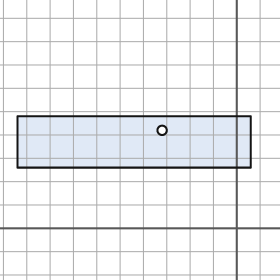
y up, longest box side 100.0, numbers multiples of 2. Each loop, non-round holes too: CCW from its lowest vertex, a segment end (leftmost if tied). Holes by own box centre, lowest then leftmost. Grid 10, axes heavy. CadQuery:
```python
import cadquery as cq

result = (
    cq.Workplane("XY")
    .moveTo(-94.0, 26.0)
    .lineTo(6.0, 26.0)
    .lineTo(6.0, 48.0)
    .lineTo(-94.0, 48.0)
    .close()
    .moveTo(-32.0, 42.0)
    .circle(2.0)
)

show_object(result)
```